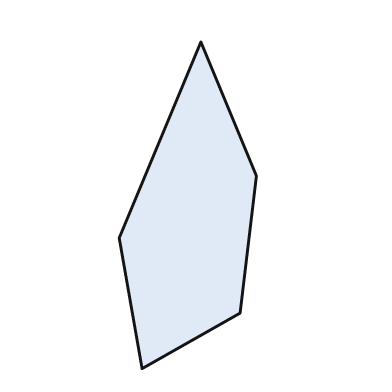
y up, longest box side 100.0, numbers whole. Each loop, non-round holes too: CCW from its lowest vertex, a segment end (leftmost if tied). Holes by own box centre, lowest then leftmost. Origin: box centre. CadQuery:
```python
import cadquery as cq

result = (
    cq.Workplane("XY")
    .moveTo(-14.0, -50.0)
    .lineTo(16.0, -33.0)
    .lineTo(21.0, 9.0)
    .lineTo(4.0, 50.0)
    .lineTo(-21.0, -10.0)
    .close()
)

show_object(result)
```